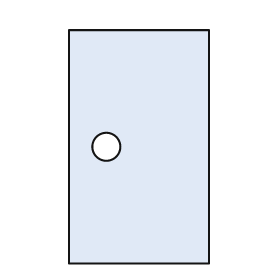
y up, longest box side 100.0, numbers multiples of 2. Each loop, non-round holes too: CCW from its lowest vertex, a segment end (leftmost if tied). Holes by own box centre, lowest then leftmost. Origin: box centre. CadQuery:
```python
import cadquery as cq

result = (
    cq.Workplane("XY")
    .moveTo(-30.0, -50.0)
    .lineTo(30.0, -50.0)
    .lineTo(30.0, 50.0)
    .lineTo(-30.0, 50.0)
    .close()
    .moveTo(-14.0, 0.0)
    .circle(6.0)
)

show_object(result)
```